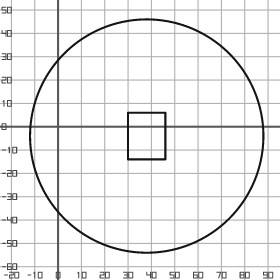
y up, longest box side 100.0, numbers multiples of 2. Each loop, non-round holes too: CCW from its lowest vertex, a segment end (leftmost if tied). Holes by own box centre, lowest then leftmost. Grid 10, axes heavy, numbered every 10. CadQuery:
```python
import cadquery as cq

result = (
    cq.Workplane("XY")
    .moveTo(38.0, -4.0)
    .circle(50.0)
    .moveTo(30.0, -14.0)
    .lineTo(46.0, -14.0)
    .lineTo(46.0, 6.0)
    .lineTo(30.0, 6.0)
    .close()
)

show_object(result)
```